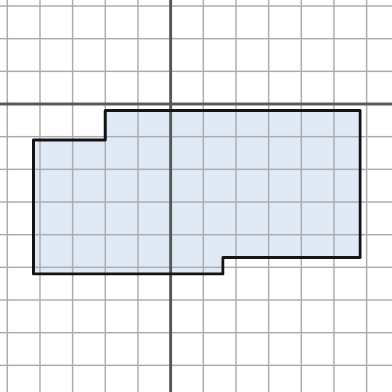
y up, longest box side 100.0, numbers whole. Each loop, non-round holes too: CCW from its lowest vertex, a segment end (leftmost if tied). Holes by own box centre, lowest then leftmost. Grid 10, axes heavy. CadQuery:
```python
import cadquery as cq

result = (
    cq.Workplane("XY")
    .moveTo(-42.0, -52.0)
    .lineTo(16.0, -52.0)
    .lineTo(16.0, -47.0)
    .lineTo(58.0, -47.0)
    .lineTo(58.0, -2.0)
    .lineTo(-20.0, -2.0)
    .lineTo(-20.0, -11.0)
    .lineTo(-42.0, -11.0)
    .close()
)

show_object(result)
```